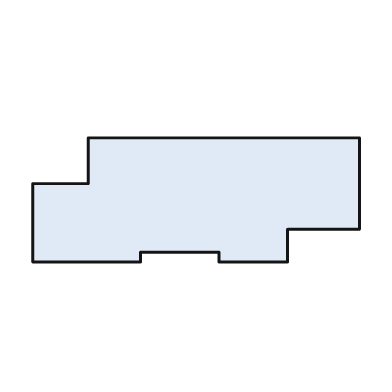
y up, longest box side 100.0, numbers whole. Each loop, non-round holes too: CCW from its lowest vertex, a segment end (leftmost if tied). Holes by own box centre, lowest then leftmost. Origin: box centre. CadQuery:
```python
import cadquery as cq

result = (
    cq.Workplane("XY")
    .moveTo(-50.0, -19.0)
    .lineTo(-17.0, -19.0)
    .lineTo(-17.0, -16.0)
    .lineTo(7.0, -16.0)
    .lineTo(7.0, -19.0)
    .lineTo(28.0, -19.0)
    .lineTo(28.0, -9.0)
    .lineTo(50.0, -9.0)
    .lineTo(50.0, 19.0)
    .lineTo(-33.0, 19.0)
    .lineTo(-33.0, 5.0)
    .lineTo(-50.0, 5.0)
    .close()
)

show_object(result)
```